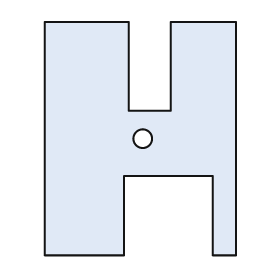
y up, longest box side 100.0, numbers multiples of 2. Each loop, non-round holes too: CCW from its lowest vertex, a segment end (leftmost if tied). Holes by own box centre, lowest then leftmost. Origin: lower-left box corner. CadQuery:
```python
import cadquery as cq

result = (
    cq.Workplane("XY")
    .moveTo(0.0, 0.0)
    .lineTo(34.0, 0.0)
    .lineTo(34.0, 34.0)
    .lineTo(72.0, 34.0)
    .lineTo(72.0, 0.0)
    .lineTo(82.0, 0.0)
    .lineTo(82.0, 100.0)
    .lineTo(54.0, 100.0)
    .lineTo(54.0, 62.0)
    .lineTo(36.0, 62.0)
    .lineTo(36.0, 100.0)
    .lineTo(0.0, 100.0)
    .close()
    .moveTo(42.0, 50.0)
    .circle(4.0)
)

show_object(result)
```